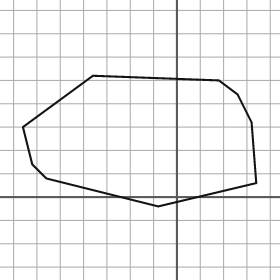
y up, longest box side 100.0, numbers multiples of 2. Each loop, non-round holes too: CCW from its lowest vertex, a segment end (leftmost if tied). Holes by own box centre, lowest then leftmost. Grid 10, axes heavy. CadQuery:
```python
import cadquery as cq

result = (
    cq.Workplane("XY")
    .moveTo(-8.0, -4.0)
    .lineTo(34.0, 6.0)
    .lineTo(32.0, 32.0)
    .lineTo(26.0, 44.0)
    .lineTo(18.0, 50.0)
    .lineTo(-36.0, 52.0)
    .lineTo(-66.0, 30.0)
    .lineTo(-62.0, 14.0)
    .lineTo(-56.0, 8.0)
    .close()
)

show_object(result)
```